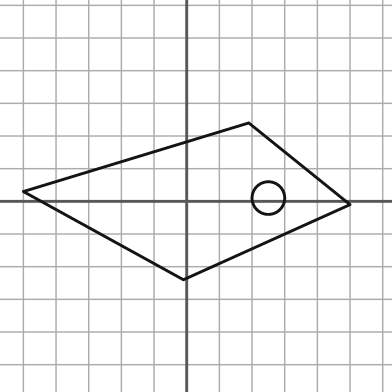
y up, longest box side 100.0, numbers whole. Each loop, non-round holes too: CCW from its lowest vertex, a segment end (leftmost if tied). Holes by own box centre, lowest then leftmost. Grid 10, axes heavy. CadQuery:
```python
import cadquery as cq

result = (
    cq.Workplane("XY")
    .moveTo(-1.0, -24.0)
    .lineTo(50.0, -1.0)
    .lineTo(19.0, 24.0)
    .lineTo(-50.0, 3.0)
    .close()
    .moveTo(25.0, 1.0)
    .circle(5.0)
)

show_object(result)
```